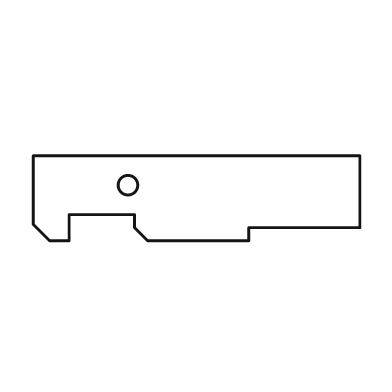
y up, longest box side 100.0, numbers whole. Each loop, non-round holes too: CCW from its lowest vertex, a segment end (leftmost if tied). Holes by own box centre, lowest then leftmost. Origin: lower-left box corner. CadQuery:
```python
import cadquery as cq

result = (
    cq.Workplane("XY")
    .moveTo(5.0, 0.0)
    .lineTo(11.0, 0.0)
    .lineTo(11.0, 8.0)
    .lineTo(31.0, 8.0)
    .lineTo(31.0, 4.0)
    .lineTo(35.0, 0.0)
    .lineTo(66.0, 0.0)
    .lineTo(66.0, 4.0)
    .lineTo(100.0, 4.0)
    .lineTo(100.0, 26.0)
    .lineTo(0.0, 26.0)
    .lineTo(0.0, 5.0)
    .close()
    .moveTo(29.0, 17.0)
    .circle(3.0)
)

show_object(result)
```